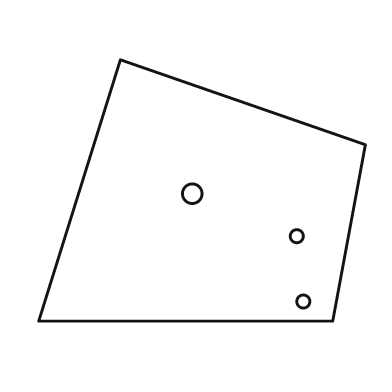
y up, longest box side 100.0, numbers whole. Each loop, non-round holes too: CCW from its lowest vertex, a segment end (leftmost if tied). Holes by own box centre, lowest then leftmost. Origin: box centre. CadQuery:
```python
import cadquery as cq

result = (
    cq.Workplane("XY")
    .moveTo(-50.0, -40.0)
    .lineTo(40.0, -40.0)
    .lineTo(50.0, 14.0)
    .lineTo(-25.0, 40.0)
    .close()
    .moveTo(31.0, -34.0)
    .circle(2.0)
    .moveTo(29.0, -14.0)
    .circle(2.0)
    .moveTo(-3.0, -1.0)
    .circle(3.0)
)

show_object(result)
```